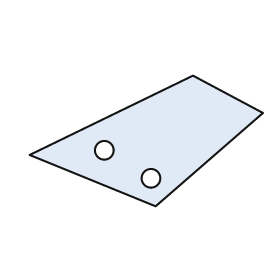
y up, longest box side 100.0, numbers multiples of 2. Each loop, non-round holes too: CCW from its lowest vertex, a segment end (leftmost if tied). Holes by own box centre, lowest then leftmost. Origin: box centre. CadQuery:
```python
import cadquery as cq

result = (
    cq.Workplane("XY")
    .moveTo(4.0, -28.0)
    .lineTo(50.0, 12.0)
    .lineTo(20.0, 28.0)
    .lineTo(-50.0, -6.0)
    .close()
    .moveTo(2.0, -16.0)
    .circle(4.0)
    .moveTo(-18.0, -4.0)
    .circle(4.0)
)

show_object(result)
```